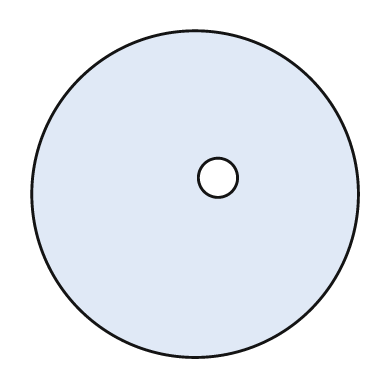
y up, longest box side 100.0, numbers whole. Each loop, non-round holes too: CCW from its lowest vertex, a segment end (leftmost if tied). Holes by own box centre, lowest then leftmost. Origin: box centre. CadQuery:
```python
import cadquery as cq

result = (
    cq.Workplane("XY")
    .moveTo(0.0, 0.0)
    .circle(50.0)
    .moveTo(7.0, 5.0)
    .circle(6.0)
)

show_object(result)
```